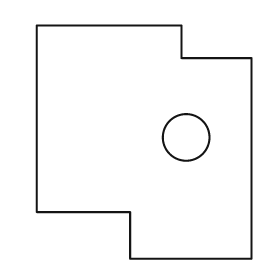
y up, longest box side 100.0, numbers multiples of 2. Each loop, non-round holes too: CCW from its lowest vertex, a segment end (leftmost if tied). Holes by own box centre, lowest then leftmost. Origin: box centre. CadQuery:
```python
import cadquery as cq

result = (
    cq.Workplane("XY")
    .moveTo(-6.0, -50.0)
    .lineTo(46.0, -50.0)
    .lineTo(46.0, 36.0)
    .lineTo(16.0, 36.0)
    .lineTo(16.0, 50.0)
    .lineTo(-46.0, 50.0)
    .lineTo(-46.0, -30.0)
    .lineTo(-6.0, -30.0)
    .close()
    .moveTo(18.0, 2.0)
    .circle(10.0)
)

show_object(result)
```